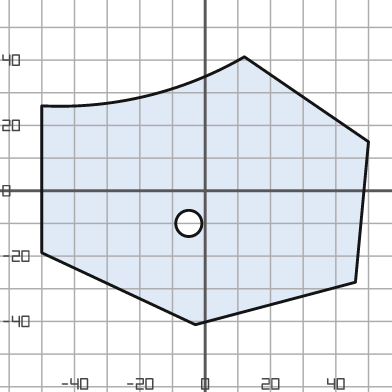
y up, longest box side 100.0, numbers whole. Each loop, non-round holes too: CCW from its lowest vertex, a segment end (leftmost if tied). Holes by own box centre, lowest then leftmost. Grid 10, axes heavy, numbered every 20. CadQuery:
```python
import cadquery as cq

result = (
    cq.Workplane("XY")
    .moveTo(-3.0, -41.0)
    .lineTo(46.0, -28.0)
    .lineTo(50.0, 15.0)
    .lineTo(12.0, 41.0)
    .threePointArc((-18.0, 29.0), (-50.0, 26.0))
    .lineTo(-50.0, -19.0)
    .close()
    .moveTo(-5.0, -10.0)
    .circle(4.0)
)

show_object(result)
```